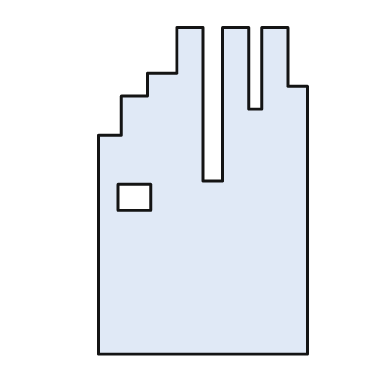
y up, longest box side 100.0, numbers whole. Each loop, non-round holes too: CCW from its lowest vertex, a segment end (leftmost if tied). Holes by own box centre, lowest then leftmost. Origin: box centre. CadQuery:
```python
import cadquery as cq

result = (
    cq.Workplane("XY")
    .moveTo(-32.0, -50.0)
    .lineTo(32.0, -50.0)
    .lineTo(32.0, 32.0)
    .lineTo(26.0, 32.0)
    .lineTo(26.0, 50.0)
    .lineTo(18.0, 50.0)
    .lineTo(18.0, 25.0)
    .lineTo(14.0, 25.0)
    .lineTo(14.0, 50.0)
    .lineTo(6.0, 50.0)
    .lineTo(6.0, 3.0)
    .lineTo(0.0, 3.0)
    .lineTo(0.0, 50.0)
    .lineTo(-8.0, 50.0)
    .lineTo(-8.0, 36.0)
    .lineTo(-17.0, 36.0)
    .lineTo(-17.0, 29.0)
    .lineTo(-25.0, 29.0)
    .lineTo(-25.0, 17.0)
    .lineTo(-32.0, 17.0)
    .close()
    .moveTo(-26.0, -6.0)
    .lineTo(-16.0, -6.0)
    .lineTo(-16.0, 2.0)
    .lineTo(-26.0, 2.0)
    .close()
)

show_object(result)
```